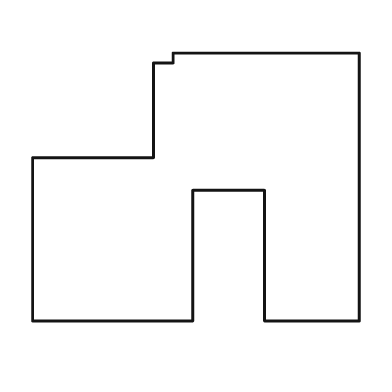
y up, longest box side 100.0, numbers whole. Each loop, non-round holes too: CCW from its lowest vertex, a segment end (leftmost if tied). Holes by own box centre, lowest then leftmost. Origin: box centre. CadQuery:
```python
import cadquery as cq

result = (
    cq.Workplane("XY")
    .moveTo(-50.0, -41.0)
    .lineTo(-1.0, -41.0)
    .lineTo(-1.0, -1.0)
    .lineTo(21.0, -1.0)
    .lineTo(21.0, -41.0)
    .lineTo(50.0, -41.0)
    .lineTo(50.0, 41.0)
    .lineTo(-7.0, 41.0)
    .lineTo(-7.0, 38.0)
    .lineTo(-13.0, 38.0)
    .lineTo(-13.0, 9.0)
    .lineTo(-50.0, 9.0)
    .close()
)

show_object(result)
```